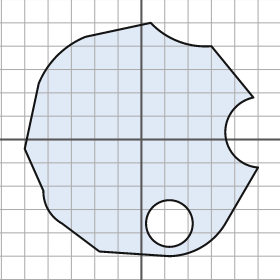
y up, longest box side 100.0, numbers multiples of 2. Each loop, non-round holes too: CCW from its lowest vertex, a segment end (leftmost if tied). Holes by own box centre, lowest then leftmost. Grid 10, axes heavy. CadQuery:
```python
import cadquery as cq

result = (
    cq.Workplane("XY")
    .moveTo(12.0, -50.0)
    .threePointArc((26.0, -46.0), (36.0, -36.0))
    .lineTo(50.0, -12.0)
    .threePointArc((36.0, 2.0), (48.0, 18.0))
    .lineTo(30.0, 40.0)
    .threePointArc((16.0, 42.0), (4.0, 50.0))
    .lineTo(-24.0, 44.0)
    .threePointArc((-36.0, 36.0), (-44.0, 24.0))
    .lineTo(-50.0, -4.0)
    .lineTo(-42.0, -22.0)
    .threePointArc((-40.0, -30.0), (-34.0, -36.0))
    .lineTo(-18.0, -48.0)
    .close()
    .moveTo(12.0, -36.0)
    .circle(10.0)
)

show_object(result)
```